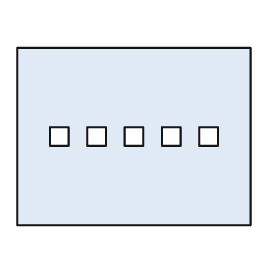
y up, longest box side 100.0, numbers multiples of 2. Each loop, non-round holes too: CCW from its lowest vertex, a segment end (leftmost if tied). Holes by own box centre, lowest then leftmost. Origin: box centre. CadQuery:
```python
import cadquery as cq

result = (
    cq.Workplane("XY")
    .moveTo(-50.0, -38.0)
    .lineTo(50.0, -38.0)
    .lineTo(50.0, 38.0)
    .lineTo(-50.0, 38.0)
    .close()
    .moveTo(-36.0, -4.0)
    .lineTo(-28.0, -4.0)
    .lineTo(-28.0, 4.0)
    .lineTo(-36.0, 4.0)
    .close()
    .moveTo(-20.0, -4.0)
    .lineTo(-12.0, -4.0)
    .lineTo(-12.0, 4.0)
    .lineTo(-20.0, 4.0)
    .close()
    .moveTo(-4.0, -4.0)
    .lineTo(4.0, -4.0)
    .lineTo(4.0, 4.0)
    .lineTo(-4.0, 4.0)
    .close()
    .moveTo(12.0, -4.0)
    .lineTo(20.0, -4.0)
    .lineTo(20.0, 4.0)
    .lineTo(12.0, 4.0)
    .close()
    .moveTo(28.0, -4.0)
    .lineTo(36.0, -4.0)
    .lineTo(36.0, 4.0)
    .lineTo(28.0, 4.0)
    .close()
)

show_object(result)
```